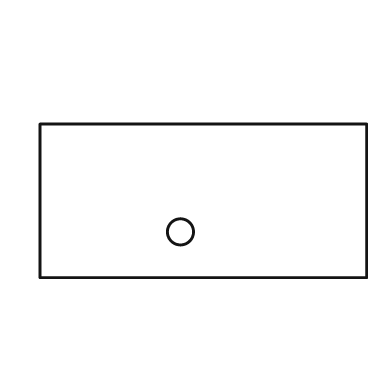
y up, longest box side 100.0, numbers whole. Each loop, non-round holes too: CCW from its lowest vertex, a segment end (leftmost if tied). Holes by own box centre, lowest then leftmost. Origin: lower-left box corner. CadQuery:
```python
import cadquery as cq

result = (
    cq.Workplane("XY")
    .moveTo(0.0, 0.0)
    .lineTo(100.0, 0.0)
    .lineTo(100.0, 47.0)
    .lineTo(0.0, 47.0)
    .close()
    .moveTo(43.0, 14.0)
    .circle(4.0)
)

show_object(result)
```